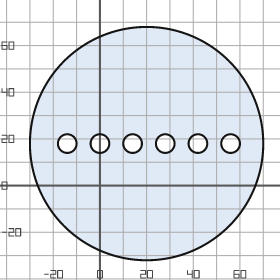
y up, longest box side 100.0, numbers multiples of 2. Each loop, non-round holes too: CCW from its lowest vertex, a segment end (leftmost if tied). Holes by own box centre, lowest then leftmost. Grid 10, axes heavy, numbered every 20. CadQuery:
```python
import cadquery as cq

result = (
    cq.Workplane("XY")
    .moveTo(20.0, 18.0)
    .circle(50.0)
    .moveTo(-14.0, 18.0)
    .circle(4.0)
    .moveTo(0.0, 18.0)
    .circle(4.0)
    .moveTo(14.0, 18.0)
    .circle(4.0)
    .moveTo(28.0, 18.0)
    .circle(4.0)
    .moveTo(42.0, 18.0)
    .circle(4.0)
    .moveTo(56.0, 18.0)
    .circle(4.0)
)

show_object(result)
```